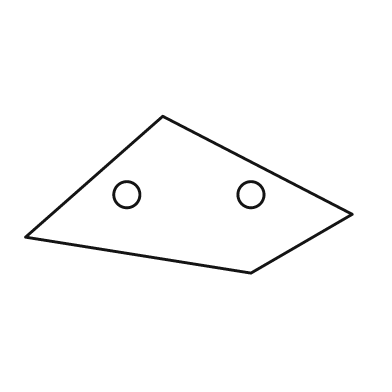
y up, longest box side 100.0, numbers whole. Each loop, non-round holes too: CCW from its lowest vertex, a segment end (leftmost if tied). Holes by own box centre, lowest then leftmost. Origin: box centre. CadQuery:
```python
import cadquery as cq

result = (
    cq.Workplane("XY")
    .moveTo(19.0, -24.0)
    .lineTo(50.0, -6.0)
    .lineTo(-8.0, 24.0)
    .lineTo(-50.0, -13.0)
    .close()
    .moveTo(-19.0, 0.0)
    .circle(4.0)
    .moveTo(19.0, 0.0)
    .circle(4.0)
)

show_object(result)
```